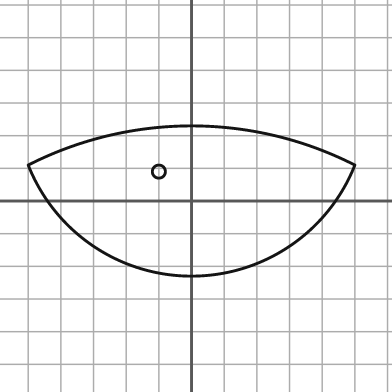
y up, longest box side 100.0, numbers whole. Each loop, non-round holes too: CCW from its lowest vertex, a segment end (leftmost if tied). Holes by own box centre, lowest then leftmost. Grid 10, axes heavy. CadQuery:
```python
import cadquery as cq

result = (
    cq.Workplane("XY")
    .moveTo(-50.0, 11.0)
    .threePointArc((0.0, -23.0), (50.0, 11.0))
    .threePointArc((0.0, 23.0), (-50.0, 11.0))
    .close()
    .moveTo(-10.0, 9.0)
    .circle(2.0)
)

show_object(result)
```